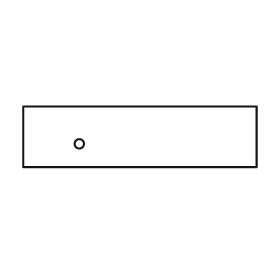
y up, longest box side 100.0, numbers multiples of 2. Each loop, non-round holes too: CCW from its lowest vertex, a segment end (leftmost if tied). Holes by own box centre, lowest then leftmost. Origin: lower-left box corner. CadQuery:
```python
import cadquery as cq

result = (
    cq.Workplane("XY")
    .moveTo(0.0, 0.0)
    .lineTo(100.0, 0.0)
    .lineTo(100.0, 26.0)
    .lineTo(0.0, 26.0)
    .close()
    .moveTo(24.0, 10.0)
    .circle(2.0)
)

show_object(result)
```